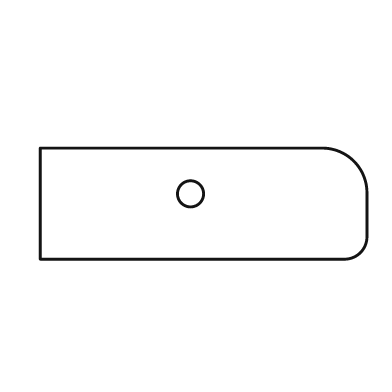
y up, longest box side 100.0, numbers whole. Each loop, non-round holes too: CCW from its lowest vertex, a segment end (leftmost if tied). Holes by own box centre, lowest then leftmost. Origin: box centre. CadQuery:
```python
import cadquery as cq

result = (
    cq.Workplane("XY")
    .moveTo(-50.0, -17.0)
    .lineTo(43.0, -17.0)
    .threePointArc((48.0, -15.0), (50.0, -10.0))
    .lineTo(50.0, 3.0)
    .threePointArc((46.0, 13.0), (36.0, 17.0))
    .lineTo(-50.0, 17.0)
    .close()
    .moveTo(-4.0, 3.0)
    .circle(4.0)
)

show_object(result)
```